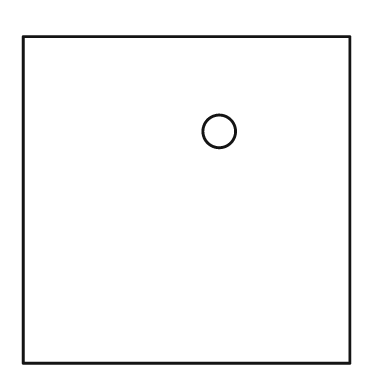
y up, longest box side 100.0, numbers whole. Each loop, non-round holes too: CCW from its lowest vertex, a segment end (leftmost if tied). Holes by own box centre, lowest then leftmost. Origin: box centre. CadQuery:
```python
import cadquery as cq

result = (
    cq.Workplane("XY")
    .moveTo(-50.0, -50.0)
    .lineTo(50.0, -50.0)
    .lineTo(50.0, 50.0)
    .lineTo(-50.0, 50.0)
    .close()
    .moveTo(10.0, 21.0)
    .circle(5.0)
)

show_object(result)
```